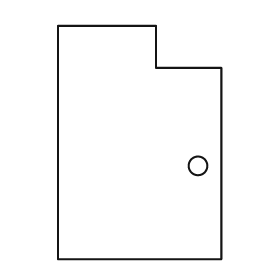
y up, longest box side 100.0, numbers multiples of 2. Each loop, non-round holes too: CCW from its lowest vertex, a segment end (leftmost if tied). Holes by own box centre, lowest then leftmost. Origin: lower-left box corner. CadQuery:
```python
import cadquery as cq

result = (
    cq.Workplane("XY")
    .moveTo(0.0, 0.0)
    .lineTo(70.0, 0.0)
    .lineTo(70.0, 82.0)
    .lineTo(42.0, 82.0)
    .lineTo(42.0, 100.0)
    .lineTo(0.0, 100.0)
    .close()
    .moveTo(60.0, 40.0)
    .circle(4.0)
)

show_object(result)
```